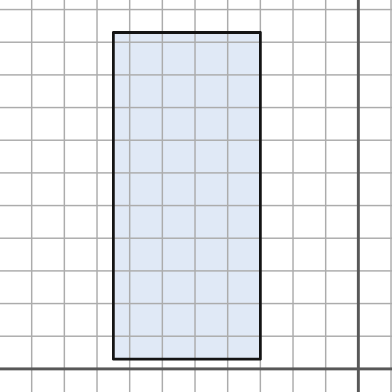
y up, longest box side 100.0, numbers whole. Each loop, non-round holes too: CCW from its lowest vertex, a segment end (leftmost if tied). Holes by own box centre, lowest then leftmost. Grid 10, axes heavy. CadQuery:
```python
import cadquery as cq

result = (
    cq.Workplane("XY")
    .moveTo(-75.0, 3.0)
    .lineTo(-30.0, 3.0)
    .lineTo(-30.0, 103.0)
    .lineTo(-75.0, 103.0)
    .close()
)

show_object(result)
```